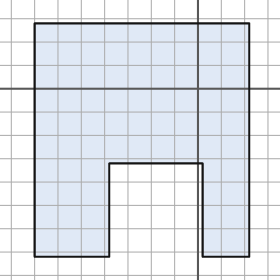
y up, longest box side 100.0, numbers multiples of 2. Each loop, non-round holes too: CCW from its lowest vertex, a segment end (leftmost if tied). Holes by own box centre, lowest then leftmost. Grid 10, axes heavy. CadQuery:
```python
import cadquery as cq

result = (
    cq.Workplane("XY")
    .moveTo(-70.0, -72.0)
    .lineTo(-38.0, -72.0)
    .lineTo(-38.0, -32.0)
    .lineTo(2.0, -32.0)
    .lineTo(2.0, -72.0)
    .lineTo(22.0, -72.0)
    .lineTo(22.0, 28.0)
    .lineTo(-70.0, 28.0)
    .close()
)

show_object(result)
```